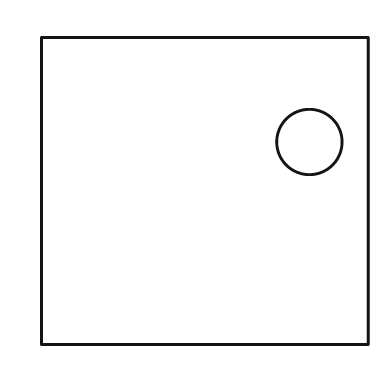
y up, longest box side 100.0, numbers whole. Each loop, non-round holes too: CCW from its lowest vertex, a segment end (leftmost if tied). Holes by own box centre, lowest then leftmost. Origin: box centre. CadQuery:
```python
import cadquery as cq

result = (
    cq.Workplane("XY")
    .moveTo(-50.0, -47.0)
    .lineTo(50.0, -47.0)
    .lineTo(50.0, 47.0)
    .lineTo(-50.0, 47.0)
    .close()
    .moveTo(32.0, 15.0)
    .circle(10.0)
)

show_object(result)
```